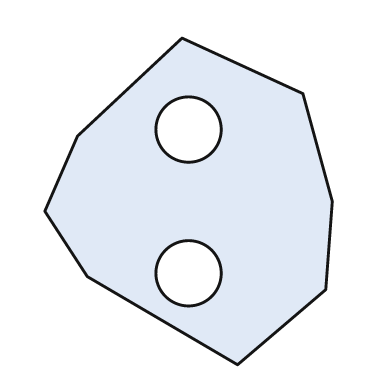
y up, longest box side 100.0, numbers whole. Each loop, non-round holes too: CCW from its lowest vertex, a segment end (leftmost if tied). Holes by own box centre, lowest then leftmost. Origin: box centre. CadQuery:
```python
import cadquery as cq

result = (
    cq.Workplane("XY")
    .moveTo(15.0, -50.0)
    .lineTo(42.0, -27.0)
    .lineTo(44.0, 0.0)
    .lineTo(35.0, 33.0)
    .lineTo(-2.0, 50.0)
    .lineTo(-34.0, 20.0)
    .lineTo(-44.0, -3.0)
    .lineTo(-31.0, -23.0)
    .close()
    .moveTo(0.0, -22.0)
    .circle(10.0)
    .moveTo(0.0, 22.0)
    .circle(10.0)
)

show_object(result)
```